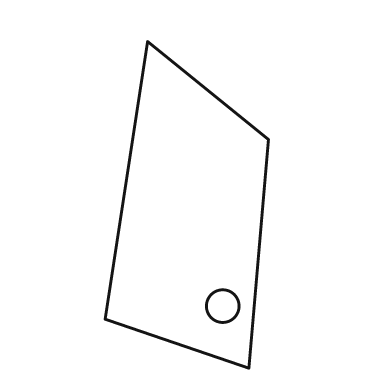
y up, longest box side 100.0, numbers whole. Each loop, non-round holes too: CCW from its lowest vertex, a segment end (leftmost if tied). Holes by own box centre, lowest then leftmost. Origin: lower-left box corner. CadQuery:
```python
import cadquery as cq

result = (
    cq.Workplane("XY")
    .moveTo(44.0, 0.0)
    .lineTo(50.0, 70.0)
    .lineTo(13.0, 100.0)
    .lineTo(0.0, 15.0)
    .close()
    .moveTo(36.0, 19.0)
    .circle(5.0)
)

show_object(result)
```